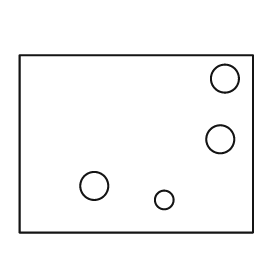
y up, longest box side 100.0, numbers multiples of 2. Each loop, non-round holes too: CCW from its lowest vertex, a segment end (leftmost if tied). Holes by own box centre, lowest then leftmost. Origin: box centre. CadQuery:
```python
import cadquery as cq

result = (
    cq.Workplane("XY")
    .moveTo(-50.0, -38.0)
    .lineTo(50.0, -38.0)
    .lineTo(50.0, 38.0)
    .lineTo(-50.0, 38.0)
    .close()
    .moveTo(12.0, -24.0)
    .circle(4.0)
    .moveTo(-18.0, -18.0)
    .circle(6.0)
    .moveTo(36.0, 2.0)
    .circle(6.0)
    .moveTo(38.0, 28.0)
    .circle(6.0)
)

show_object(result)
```